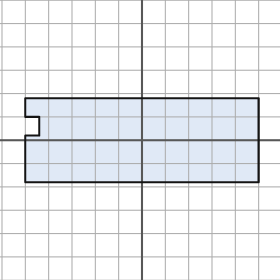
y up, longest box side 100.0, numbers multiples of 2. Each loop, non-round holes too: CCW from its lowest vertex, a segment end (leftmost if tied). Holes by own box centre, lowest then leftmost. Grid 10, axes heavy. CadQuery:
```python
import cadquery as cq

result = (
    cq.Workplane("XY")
    .moveTo(-50.0, -18.0)
    .lineTo(50.0, -18.0)
    .lineTo(50.0, 18.0)
    .lineTo(-50.0, 18.0)
    .lineTo(-50.0, 10.0)
    .lineTo(-44.0, 10.0)
    .lineTo(-44.0, 2.0)
    .lineTo(-50.0, 2.0)
    .close()
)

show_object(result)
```